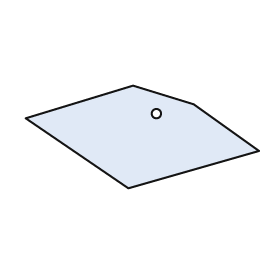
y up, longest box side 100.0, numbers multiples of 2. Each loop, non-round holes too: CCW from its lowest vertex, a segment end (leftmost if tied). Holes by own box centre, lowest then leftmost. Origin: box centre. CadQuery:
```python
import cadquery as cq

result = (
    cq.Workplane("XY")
    .moveTo(-6.0, -22.0)
    .lineTo(50.0, -6.0)
    .lineTo(22.0, 14.0)
    .lineTo(-4.0, 22.0)
    .lineTo(-50.0, 8.0)
    .close()
    .moveTo(6.0, 10.0)
    .circle(2.0)
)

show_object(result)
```